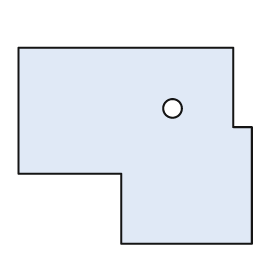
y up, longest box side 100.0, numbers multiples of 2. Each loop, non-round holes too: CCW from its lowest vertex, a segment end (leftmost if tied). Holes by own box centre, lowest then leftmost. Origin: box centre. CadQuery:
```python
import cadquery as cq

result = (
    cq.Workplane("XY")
    .moveTo(-6.0, -42.0)
    .lineTo(50.0, -42.0)
    .lineTo(50.0, 8.0)
    .lineTo(42.0, 8.0)
    .lineTo(42.0, 42.0)
    .lineTo(-50.0, 42.0)
    .lineTo(-50.0, -12.0)
    .lineTo(-6.0, -12.0)
    .close()
    .moveTo(16.0, 16.0)
    .circle(4.0)
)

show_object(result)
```